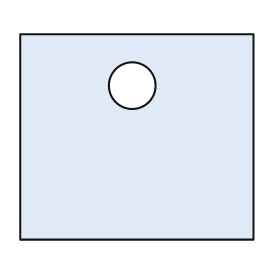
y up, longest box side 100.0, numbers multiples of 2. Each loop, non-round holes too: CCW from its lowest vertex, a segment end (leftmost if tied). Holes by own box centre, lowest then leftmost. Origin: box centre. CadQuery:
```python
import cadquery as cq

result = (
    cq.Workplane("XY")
    .moveTo(-50.0, -44.0)
    .lineTo(50.0, -44.0)
    .lineTo(50.0, 44.0)
    .lineTo(-50.0, 44.0)
    .close()
    .moveTo(-2.0, 22.0)
    .circle(10.0)
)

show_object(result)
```